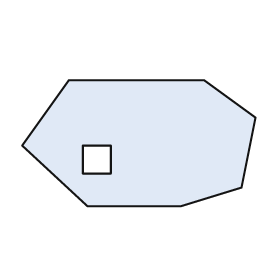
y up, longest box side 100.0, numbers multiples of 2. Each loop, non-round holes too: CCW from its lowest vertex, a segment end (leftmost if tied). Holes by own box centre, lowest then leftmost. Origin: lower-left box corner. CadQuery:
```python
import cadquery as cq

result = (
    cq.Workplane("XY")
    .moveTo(28.0, 0.0)
    .lineTo(68.0, 0.0)
    .lineTo(94.0, 8.0)
    .lineTo(100.0, 38.0)
    .lineTo(78.0, 54.0)
    .lineTo(20.0, 54.0)
    .lineTo(0.0, 26.0)
    .close()
    .moveTo(26.0, 14.0)
    .lineTo(38.0, 14.0)
    .lineTo(38.0, 26.0)
    .lineTo(26.0, 26.0)
    .close()
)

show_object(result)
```